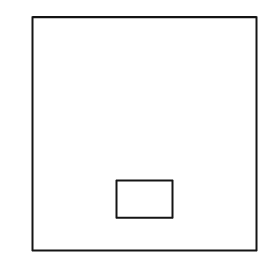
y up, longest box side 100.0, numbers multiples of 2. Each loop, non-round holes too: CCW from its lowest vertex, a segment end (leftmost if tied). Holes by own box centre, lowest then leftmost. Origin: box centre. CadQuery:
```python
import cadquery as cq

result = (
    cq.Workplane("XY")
    .moveTo(-48.0, -50.0)
    .lineTo(48.0, -50.0)
    .lineTo(48.0, 50.0)
    .lineTo(-48.0, 50.0)
    .close()
    .moveTo(-12.0, -36.0)
    .lineTo(12.0, -36.0)
    .lineTo(12.0, -20.0)
    .lineTo(-12.0, -20.0)
    .close()
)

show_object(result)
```